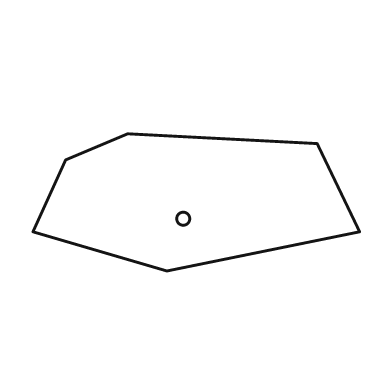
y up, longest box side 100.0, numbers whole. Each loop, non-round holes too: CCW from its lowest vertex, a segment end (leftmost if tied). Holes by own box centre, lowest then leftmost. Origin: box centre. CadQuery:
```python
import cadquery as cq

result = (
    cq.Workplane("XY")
    .moveTo(-9.0, -21.0)
    .lineTo(50.0, -9.0)
    .lineTo(37.0, 18.0)
    .lineTo(-21.0, 21.0)
    .lineTo(-40.0, 13.0)
    .lineTo(-50.0, -9.0)
    .close()
    .moveTo(-4.0, -5.0)
    .circle(2.0)
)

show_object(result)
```